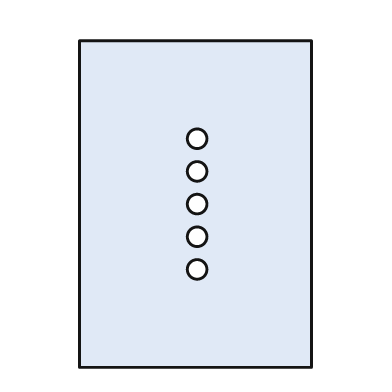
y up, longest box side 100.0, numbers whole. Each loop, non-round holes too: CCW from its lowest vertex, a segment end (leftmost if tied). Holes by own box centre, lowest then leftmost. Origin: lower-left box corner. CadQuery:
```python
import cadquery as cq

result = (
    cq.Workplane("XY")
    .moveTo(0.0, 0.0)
    .lineTo(71.0, 0.0)
    .lineTo(71.0, 100.0)
    .lineTo(0.0, 100.0)
    .close()
    .moveTo(36.0, 30.0)
    .circle(3.0)
    .moveTo(36.0, 40.0)
    .circle(3.0)
    .moveTo(36.0, 50.0)
    .circle(3.0)
    .moveTo(36.0, 60.0)
    .circle(3.0)
    .moveTo(36.0, 70.0)
    .circle(3.0)
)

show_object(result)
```